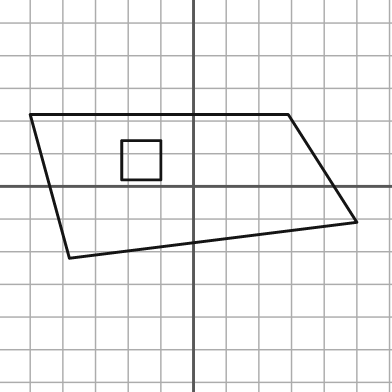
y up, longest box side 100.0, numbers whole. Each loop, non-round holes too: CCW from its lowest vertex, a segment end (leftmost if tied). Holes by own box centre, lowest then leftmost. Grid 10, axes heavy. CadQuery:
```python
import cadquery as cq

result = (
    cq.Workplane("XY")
    .moveTo(-38.0, -22.0)
    .lineTo(50.0, -11.0)
    .lineTo(29.0, 22.0)
    .lineTo(-50.0, 22.0)
    .close()
    .moveTo(-22.0, 2.0)
    .lineTo(-10.0, 2.0)
    .lineTo(-10.0, 14.0)
    .lineTo(-22.0, 14.0)
    .close()
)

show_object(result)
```